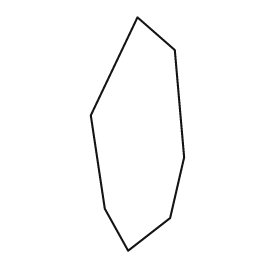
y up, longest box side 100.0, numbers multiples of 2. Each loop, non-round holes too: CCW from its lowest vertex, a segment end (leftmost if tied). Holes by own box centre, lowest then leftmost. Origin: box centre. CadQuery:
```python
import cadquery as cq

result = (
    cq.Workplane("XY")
    .moveTo(-4.0, -50.0)
    .lineTo(14.0, -36.0)
    .lineTo(20.0, -10.0)
    .lineTo(16.0, 36.0)
    .lineTo(0.0, 50.0)
    .lineTo(-20.0, 8.0)
    .lineTo(-14.0, -32.0)
    .close()
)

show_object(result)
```